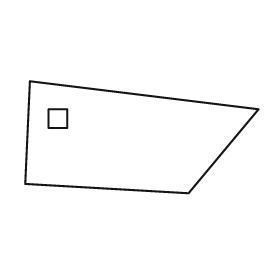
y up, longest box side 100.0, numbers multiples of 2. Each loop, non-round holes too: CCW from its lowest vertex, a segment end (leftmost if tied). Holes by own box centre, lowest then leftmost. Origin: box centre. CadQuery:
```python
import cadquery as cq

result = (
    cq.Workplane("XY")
    .moveTo(20.0, -24.0)
    .lineTo(50.0, 12.0)
    .lineTo(-48.0, 24.0)
    .lineTo(-50.0, -20.0)
    .close()
    .moveTo(-40.0, 4.0)
    .lineTo(-32.0, 4.0)
    .lineTo(-32.0, 12.0)
    .lineTo(-40.0, 12.0)
    .close()
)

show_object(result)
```